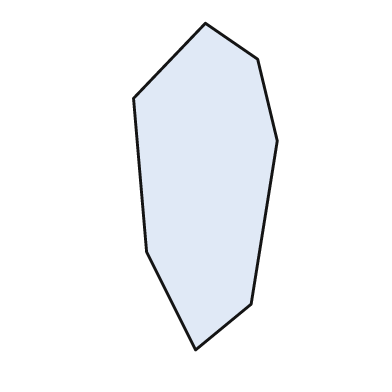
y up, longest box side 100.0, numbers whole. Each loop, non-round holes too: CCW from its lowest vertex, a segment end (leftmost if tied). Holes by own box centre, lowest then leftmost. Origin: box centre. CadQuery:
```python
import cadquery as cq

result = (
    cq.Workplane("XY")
    .moveTo(-3.0, -50.0)
    .lineTo(14.0, -36.0)
    .lineTo(22.0, 14.0)
    .lineTo(16.0, 39.0)
    .lineTo(0.0, 50.0)
    .lineTo(-22.0, 27.0)
    .lineTo(-18.0, -20.0)
    .close()
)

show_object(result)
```